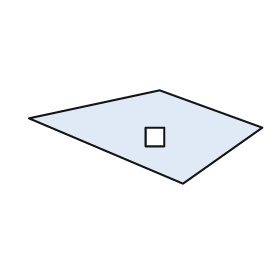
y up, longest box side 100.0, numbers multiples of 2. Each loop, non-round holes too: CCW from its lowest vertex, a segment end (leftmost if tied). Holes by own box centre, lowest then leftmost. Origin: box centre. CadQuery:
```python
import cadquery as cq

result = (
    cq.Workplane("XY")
    .moveTo(16.0, -20.0)
    .lineTo(50.0, 4.0)
    .lineTo(6.0, 20.0)
    .lineTo(-50.0, 8.0)
    .close()
    .moveTo(0.0, -4.0)
    .lineTo(8.0, -4.0)
    .lineTo(8.0, 4.0)
    .lineTo(0.0, 4.0)
    .close()
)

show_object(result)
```